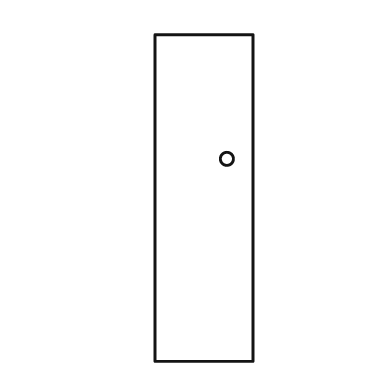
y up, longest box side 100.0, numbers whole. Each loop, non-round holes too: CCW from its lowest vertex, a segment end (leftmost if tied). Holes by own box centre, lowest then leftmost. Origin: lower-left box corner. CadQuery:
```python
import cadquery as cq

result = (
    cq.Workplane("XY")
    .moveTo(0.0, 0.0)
    .lineTo(30.0, 0.0)
    .lineTo(30.0, 100.0)
    .lineTo(0.0, 100.0)
    .close()
    .moveTo(22.0, 62.0)
    .circle(2.0)
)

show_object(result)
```